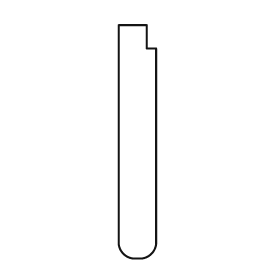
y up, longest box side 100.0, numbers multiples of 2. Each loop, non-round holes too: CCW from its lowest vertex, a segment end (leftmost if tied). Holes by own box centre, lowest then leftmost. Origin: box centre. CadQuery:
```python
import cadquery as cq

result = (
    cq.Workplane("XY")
    .moveTo(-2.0, -50.0)
    .lineTo(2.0, -50.0)
    .threePointArc((6.0, -48.0), (8.0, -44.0))
    .lineTo(8.0, 40.0)
    .lineTo(4.0, 40.0)
    .lineTo(4.0, 50.0)
    .lineTo(-8.0, 50.0)
    .lineTo(-8.0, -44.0)
    .threePointArc((-6.0, -48.0), (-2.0, -50.0))
    .close()
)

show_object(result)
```